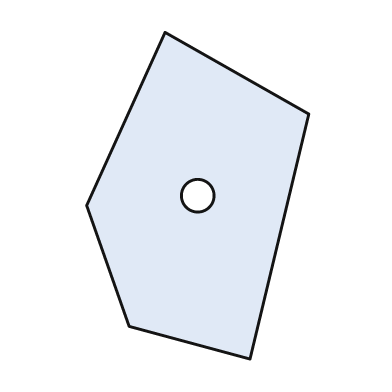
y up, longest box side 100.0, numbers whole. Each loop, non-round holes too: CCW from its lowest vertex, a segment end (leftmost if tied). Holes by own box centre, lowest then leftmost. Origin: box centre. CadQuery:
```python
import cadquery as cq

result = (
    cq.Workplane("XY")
    .moveTo(16.0, -50.0)
    .lineTo(34.0, 25.0)
    .lineTo(-10.0, 50.0)
    .lineTo(-34.0, -3.0)
    .lineTo(-21.0, -40.0)
    .close()
    .moveTo(0.0, 0.0)
    .circle(5.0)
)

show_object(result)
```